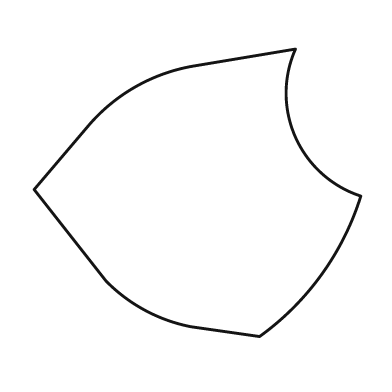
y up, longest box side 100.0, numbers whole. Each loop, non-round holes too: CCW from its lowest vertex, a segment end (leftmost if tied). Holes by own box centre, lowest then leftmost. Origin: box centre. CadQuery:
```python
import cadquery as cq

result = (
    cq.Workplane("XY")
    .moveTo(19.0, -44.0)
    .threePointArc((38.0, -25.0), (50.0, -1.0))
    .threePointArc((30.0, 17.0), (30.0, 44.0))
    .lineTo(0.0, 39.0)
    .threePointArc((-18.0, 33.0), (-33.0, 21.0))
    .lineTo(-50.0, 1.0)
    .lineTo(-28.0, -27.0)
    .threePointArc((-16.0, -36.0), (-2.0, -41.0))
    .close()
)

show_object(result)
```